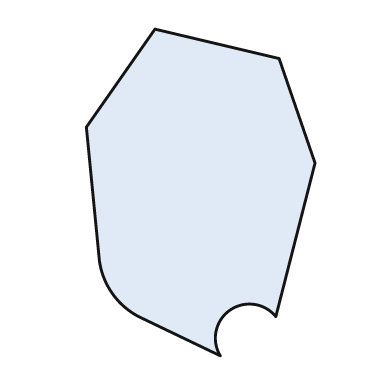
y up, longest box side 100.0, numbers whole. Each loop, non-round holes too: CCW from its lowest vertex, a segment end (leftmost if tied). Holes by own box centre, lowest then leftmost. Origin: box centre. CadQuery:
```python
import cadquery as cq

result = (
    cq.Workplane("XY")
    .moveTo(6.0, -50.0)
    .threePointArc((9.0, -36.0), (23.0, -38.0))
    .lineTo(35.0, 9.0)
    .lineTo(24.0, 41.0)
    .lineTo(-14.0, 50.0)
    .lineTo(-35.0, 20.0)
    .lineTo(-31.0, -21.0)
    .threePointArc((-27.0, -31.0), (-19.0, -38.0))
    .close()
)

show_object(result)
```